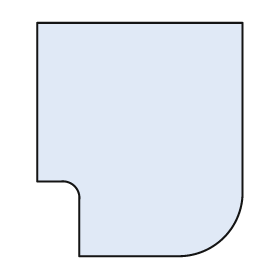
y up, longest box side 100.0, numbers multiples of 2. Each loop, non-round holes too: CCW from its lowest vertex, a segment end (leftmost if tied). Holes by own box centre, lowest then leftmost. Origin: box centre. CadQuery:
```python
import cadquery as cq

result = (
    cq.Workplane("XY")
    .moveTo(-26.0, -50.0)
    .lineTo(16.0, -50.0)
    .threePointArc((36.0, -42.0), (44.0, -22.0))
    .lineTo(44.0, 50.0)
    .lineTo(-44.0, 50.0)
    .lineTo(-44.0, -18.0)
    .lineTo(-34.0, -18.0)
    .threePointArc((-28.0, -20.0), (-26.0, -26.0))
    .close()
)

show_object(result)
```